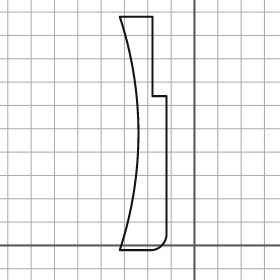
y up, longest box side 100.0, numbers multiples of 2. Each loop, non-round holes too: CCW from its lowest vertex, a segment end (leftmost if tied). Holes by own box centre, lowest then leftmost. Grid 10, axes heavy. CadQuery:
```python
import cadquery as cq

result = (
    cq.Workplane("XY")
    .moveTo(-32.0, -2.0)
    .lineTo(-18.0, -2.0)
    .threePointArc((-14.0, 0.0), (-12.0, 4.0))
    .lineTo(-12.0, 64.0)
    .lineTo(-18.0, 64.0)
    .lineTo(-18.0, 98.0)
    .lineTo(-32.0, 98.0)
    .threePointArc((-24.0, 48.0), (-32.0, -2.0))
    .close()
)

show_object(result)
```